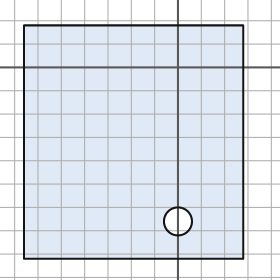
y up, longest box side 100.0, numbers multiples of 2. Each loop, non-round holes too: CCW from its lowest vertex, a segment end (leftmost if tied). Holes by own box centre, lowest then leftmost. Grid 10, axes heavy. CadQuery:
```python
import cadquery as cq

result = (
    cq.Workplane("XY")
    .moveTo(-66.0, -82.0)
    .lineTo(28.0, -82.0)
    .lineTo(28.0, 18.0)
    .lineTo(-66.0, 18.0)
    .close()
    .moveTo(0.0, -66.0)
    .circle(6.0)
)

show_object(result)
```